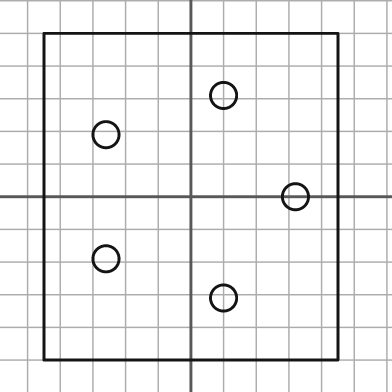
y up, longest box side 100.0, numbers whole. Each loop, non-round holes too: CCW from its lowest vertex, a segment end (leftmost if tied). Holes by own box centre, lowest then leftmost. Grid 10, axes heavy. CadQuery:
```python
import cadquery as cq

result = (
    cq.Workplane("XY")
    .moveTo(-45.0, -50.0)
    .lineTo(45.0, -50.0)
    .lineTo(45.0, 50.0)
    .lineTo(-45.0, 50.0)
    .close()
    .moveTo(10.0, -31.0)
    .circle(4.0)
    .moveTo(-26.0, -19.0)
    .circle(4.0)
    .moveTo(32.0, 0.0)
    .circle(4.0)
    .moveTo(-26.0, 19.0)
    .circle(4.0)
    .moveTo(10.0, 31.0)
    .circle(4.0)
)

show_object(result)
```